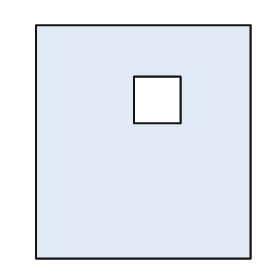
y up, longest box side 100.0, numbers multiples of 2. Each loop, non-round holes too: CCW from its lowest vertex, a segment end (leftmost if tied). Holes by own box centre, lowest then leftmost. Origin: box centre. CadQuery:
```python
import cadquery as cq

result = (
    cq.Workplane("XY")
    .moveTo(-46.0, -50.0)
    .lineTo(46.0, -50.0)
    .lineTo(46.0, 50.0)
    .lineTo(-46.0, 50.0)
    .close()
    .moveTo(-4.0, 8.0)
    .lineTo(16.0, 8.0)
    .lineTo(16.0, 28.0)
    .lineTo(-4.0, 28.0)
    .close()
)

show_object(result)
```